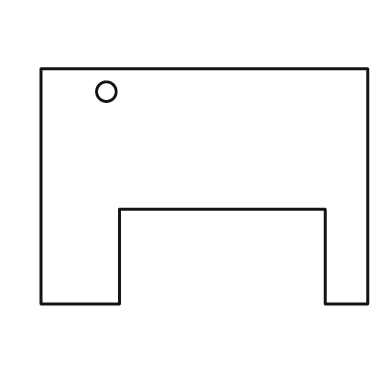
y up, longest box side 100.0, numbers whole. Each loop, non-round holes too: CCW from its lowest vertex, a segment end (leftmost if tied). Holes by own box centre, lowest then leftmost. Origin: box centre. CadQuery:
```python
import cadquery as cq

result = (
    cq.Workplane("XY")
    .moveTo(-50.0, -36.0)
    .lineTo(-26.0, -36.0)
    .lineTo(-26.0, -7.0)
    .lineTo(37.0, -7.0)
    .lineTo(37.0, -36.0)
    .lineTo(50.0, -36.0)
    .lineTo(50.0, 36.0)
    .lineTo(-50.0, 36.0)
    .close()
    .moveTo(-30.0, 29.0)
    .circle(3.0)
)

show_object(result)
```